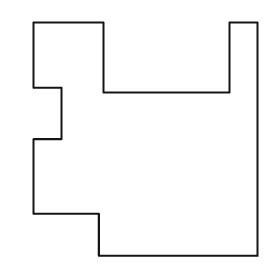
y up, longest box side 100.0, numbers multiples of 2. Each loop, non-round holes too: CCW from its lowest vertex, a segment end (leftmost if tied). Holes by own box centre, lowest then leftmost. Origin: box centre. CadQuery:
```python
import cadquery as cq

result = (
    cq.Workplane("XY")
    .moveTo(-20.0, -50.0)
    .lineTo(48.0, -50.0)
    .lineTo(48.0, 50.0)
    .lineTo(36.0, 50.0)
    .lineTo(36.0, 20.0)
    .lineTo(-18.0, 20.0)
    .lineTo(-18.0, 50.0)
    .lineTo(-48.0, 50.0)
    .lineTo(-48.0, 22.0)
    .lineTo(-36.0, 22.0)
    .lineTo(-36.0, 0.0)
    .lineTo(-48.0, 0.0)
    .lineTo(-48.0, -32.0)
    .lineTo(-20.0, -32.0)
    .close()
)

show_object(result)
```